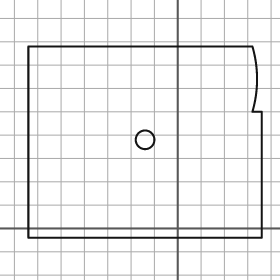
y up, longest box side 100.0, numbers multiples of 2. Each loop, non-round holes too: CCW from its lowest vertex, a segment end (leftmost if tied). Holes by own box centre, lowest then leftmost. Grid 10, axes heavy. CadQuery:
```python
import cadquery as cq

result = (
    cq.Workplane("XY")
    .moveTo(-64.0, -4.0)
    .lineTo(36.0, -4.0)
    .lineTo(36.0, 50.0)
    .lineTo(32.0, 50.0)
    .threePointArc((34.0, 64.0), (32.0, 78.0))
    .lineTo(-64.0, 78.0)
    .close()
    .moveTo(-14.0, 38.0)
    .circle(4.0)
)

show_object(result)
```